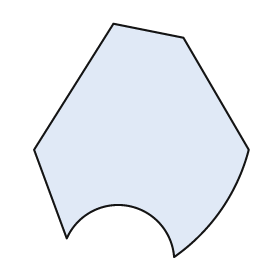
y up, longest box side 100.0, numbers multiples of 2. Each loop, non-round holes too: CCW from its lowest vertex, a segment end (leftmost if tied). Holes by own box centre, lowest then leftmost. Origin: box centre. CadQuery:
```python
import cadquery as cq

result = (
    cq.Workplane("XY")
    .moveTo(14.0, -50.0)
    .threePointArc((34.0, -30.0), (46.0, -4.0))
    .lineTo(18.0, 44.0)
    .lineTo(-12.0, 50.0)
    .lineTo(-46.0, -4.0)
    .lineTo(-32.0, -42.0)
    .threePointArc((-6.0, -28.0), (14.0, -50.0))
    .close()
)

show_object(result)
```